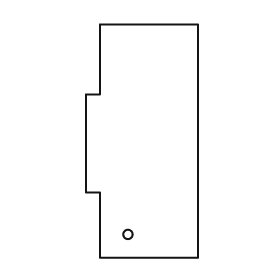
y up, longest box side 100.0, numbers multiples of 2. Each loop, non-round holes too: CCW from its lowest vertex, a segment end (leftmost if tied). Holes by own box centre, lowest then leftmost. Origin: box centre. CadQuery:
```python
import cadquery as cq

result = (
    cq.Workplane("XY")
    .moveTo(-18.0, -50.0)
    .lineTo(24.0, -50.0)
    .lineTo(24.0, 50.0)
    .lineTo(-18.0, 50.0)
    .lineTo(-18.0, 20.0)
    .lineTo(-24.0, 20.0)
    .lineTo(-24.0, -22.0)
    .lineTo(-18.0, -22.0)
    .close()
    .moveTo(-6.0, -40.0)
    .circle(2.0)
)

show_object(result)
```